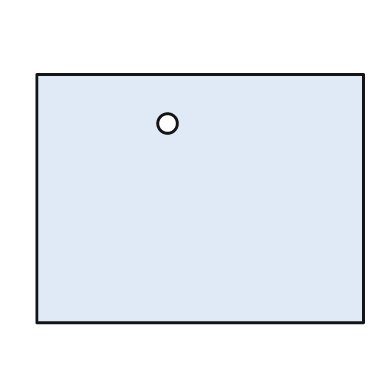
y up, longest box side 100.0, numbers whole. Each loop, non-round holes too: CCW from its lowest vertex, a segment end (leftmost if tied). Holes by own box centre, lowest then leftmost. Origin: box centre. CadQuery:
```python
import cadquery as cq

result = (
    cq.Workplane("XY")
    .moveTo(-50.0, -38.0)
    .lineTo(50.0, -38.0)
    .lineTo(50.0, 38.0)
    .lineTo(-50.0, 38.0)
    .close()
    .moveTo(-10.0, 23.0)
    .circle(3.0)
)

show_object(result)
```